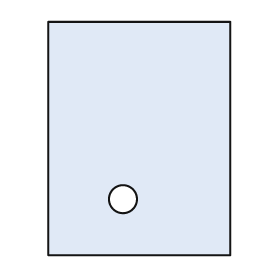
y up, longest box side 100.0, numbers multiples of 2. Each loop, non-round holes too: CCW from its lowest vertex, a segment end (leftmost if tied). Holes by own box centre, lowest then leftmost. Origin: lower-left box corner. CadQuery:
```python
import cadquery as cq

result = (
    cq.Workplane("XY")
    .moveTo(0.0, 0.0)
    .lineTo(78.0, 0.0)
    .lineTo(78.0, 100.0)
    .lineTo(0.0, 100.0)
    .close()
    .moveTo(32.0, 24.0)
    .circle(6.0)
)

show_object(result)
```